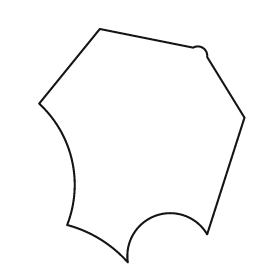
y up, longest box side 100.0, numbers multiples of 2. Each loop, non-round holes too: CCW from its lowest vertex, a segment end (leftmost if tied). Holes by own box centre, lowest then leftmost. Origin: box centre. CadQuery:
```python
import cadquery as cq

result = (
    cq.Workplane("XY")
    .moveTo(-6.0, -50.0)
    .threePointArc((6.0, -30.0), (28.0, -38.0))
    .lineTo(44.0, 12.0)
    .lineTo(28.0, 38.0)
    .threePointArc((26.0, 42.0), (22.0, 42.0))
    .lineTo(-18.0, 50.0)
    .lineTo(-44.0, 18.0)
    .threePointArc((-30.0, -6.0), (-32.0, -34.0))
    .threePointArc((-18.0, -40.0), (-6.0, -50.0))
    .close()
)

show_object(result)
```